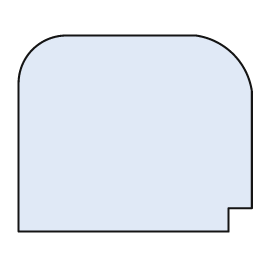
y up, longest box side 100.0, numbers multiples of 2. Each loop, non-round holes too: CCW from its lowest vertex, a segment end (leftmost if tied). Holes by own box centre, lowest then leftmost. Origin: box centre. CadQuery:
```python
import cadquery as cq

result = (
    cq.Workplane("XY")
    .moveTo(-50.0, -42.0)
    .lineTo(40.0, -42.0)
    .lineTo(40.0, -32.0)
    .lineTo(50.0, -32.0)
    .lineTo(50.0, 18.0)
    .threePointArc((42.0, 34.0), (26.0, 42.0))
    .lineTo(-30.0, 42.0)
    .threePointArc((-44.0, 36.0), (-50.0, 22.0))
    .close()
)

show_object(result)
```